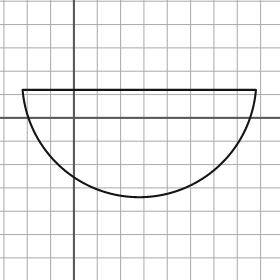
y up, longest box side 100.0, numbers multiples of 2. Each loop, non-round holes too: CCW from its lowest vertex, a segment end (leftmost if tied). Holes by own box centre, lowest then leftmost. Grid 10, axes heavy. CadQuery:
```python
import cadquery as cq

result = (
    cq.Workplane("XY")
    .moveTo(-22.0, 12.0)
    .threePointArc((28.0, -34.0), (78.0, 12.0))
    .close()
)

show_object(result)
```